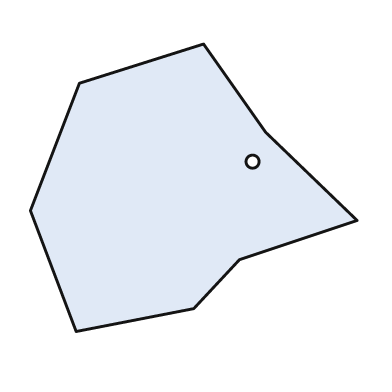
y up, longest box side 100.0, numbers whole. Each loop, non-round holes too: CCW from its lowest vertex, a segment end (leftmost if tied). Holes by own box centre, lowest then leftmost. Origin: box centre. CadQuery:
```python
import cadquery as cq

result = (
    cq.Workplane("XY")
    .moveTo(-36.0, -44.0)
    .lineTo(0.0, -37.0)
    .lineTo(14.0, -22.0)
    .lineTo(50.0, -10.0)
    .lineTo(22.0, 17.0)
    .lineTo(3.0, 44.0)
    .lineTo(-35.0, 32.0)
    .lineTo(-50.0, -7.0)
    .close()
    .moveTo(18.0, 8.0)
    .circle(2.0)
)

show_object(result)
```